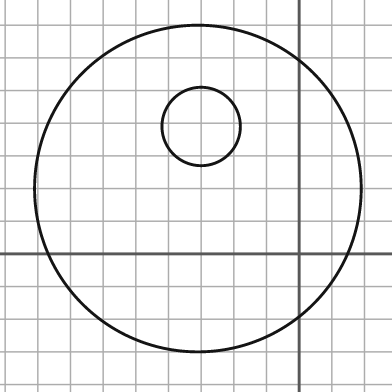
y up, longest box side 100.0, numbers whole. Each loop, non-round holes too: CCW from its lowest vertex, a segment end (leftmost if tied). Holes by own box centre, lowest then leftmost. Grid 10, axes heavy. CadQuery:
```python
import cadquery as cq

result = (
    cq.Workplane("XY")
    .moveTo(-31.0, 20.0)
    .circle(50.0)
    .moveTo(-30.0, 39.0)
    .circle(12.0)
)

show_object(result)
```